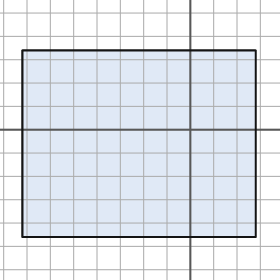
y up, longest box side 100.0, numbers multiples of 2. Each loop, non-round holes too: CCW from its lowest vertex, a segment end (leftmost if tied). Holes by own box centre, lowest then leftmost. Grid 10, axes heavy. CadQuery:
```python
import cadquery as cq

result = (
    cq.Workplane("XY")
    .moveTo(-72.0, -46.0)
    .lineTo(28.0, -46.0)
    .lineTo(28.0, 34.0)
    .lineTo(-72.0, 34.0)
    .close()
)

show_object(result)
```